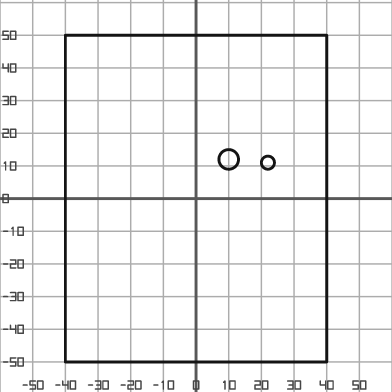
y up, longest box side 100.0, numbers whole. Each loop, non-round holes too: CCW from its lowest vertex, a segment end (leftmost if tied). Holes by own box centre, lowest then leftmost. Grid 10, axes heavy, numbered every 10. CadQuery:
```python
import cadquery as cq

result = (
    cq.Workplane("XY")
    .moveTo(-40.0, -50.0)
    .lineTo(40.0, -50.0)
    .lineTo(40.0, 50.0)
    .lineTo(-40.0, 50.0)
    .close()
    .moveTo(22.0, 11.0)
    .circle(2.0)
    .moveTo(10.0, 12.0)
    .circle(3.0)
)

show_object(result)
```